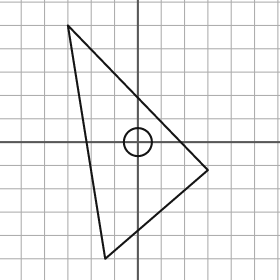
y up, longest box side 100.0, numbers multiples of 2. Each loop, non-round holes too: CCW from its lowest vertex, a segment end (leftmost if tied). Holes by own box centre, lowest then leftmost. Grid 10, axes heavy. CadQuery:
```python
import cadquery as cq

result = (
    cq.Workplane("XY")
    .moveTo(-14.0, -50.0)
    .lineTo(30.0, -12.0)
    .lineTo(-30.0, 50.0)
    .close()
    .moveTo(0.0, 0.0)
    .circle(6.0)
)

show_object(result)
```